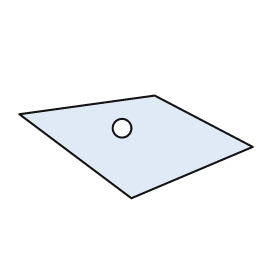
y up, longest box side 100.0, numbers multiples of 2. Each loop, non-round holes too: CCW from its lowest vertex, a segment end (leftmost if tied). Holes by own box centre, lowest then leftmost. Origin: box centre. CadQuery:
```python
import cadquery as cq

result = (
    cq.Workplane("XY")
    .moveTo(-2.0, -22.0)
    .lineTo(50.0, 0.0)
    .lineTo(8.0, 22.0)
    .lineTo(-50.0, 14.0)
    .close()
    .moveTo(-6.0, 8.0)
    .circle(4.0)
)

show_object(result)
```